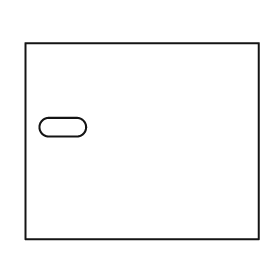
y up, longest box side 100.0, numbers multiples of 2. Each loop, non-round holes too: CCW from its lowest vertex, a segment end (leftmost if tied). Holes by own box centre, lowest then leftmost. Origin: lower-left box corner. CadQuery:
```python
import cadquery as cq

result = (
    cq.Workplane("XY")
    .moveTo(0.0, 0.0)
    .lineTo(100.0, 0.0)
    .lineTo(100.0, 84.0)
    .lineTo(0.0, 84.0)
    .close()
    .moveTo(10.0, 44.0)
    .lineTo(22.0, 44.0)
    .threePointArc((26.0, 48.0), (22.0, 52.0))
    .lineTo(10.0, 52.0)
    .threePointArc((6.0, 48.0), (10.0, 44.0))
    .close()
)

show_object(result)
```